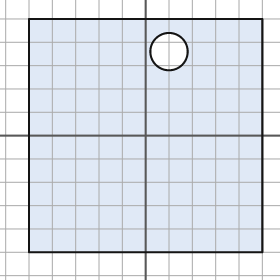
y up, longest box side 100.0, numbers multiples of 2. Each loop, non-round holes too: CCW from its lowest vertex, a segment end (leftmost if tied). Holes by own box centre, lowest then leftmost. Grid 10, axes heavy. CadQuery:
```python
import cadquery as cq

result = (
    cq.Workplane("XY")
    .moveTo(-50.0, -50.0)
    .lineTo(50.0, -50.0)
    .lineTo(50.0, 50.0)
    .lineTo(-50.0, 50.0)
    .close()
    .moveTo(10.0, 36.0)
    .circle(8.0)
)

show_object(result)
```